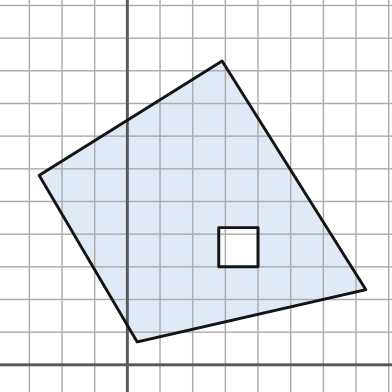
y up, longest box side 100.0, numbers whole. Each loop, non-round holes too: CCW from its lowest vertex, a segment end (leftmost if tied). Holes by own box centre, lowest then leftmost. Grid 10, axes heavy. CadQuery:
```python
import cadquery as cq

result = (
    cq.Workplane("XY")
    .moveTo(3.0, 7.0)
    .lineTo(73.0, 23.0)
    .lineTo(29.0, 93.0)
    .lineTo(-27.0, 58.0)
    .close()
    .moveTo(28.0, 30.0)
    .lineTo(40.0, 30.0)
    .lineTo(40.0, 42.0)
    .lineTo(28.0, 42.0)
    .close()
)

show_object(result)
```